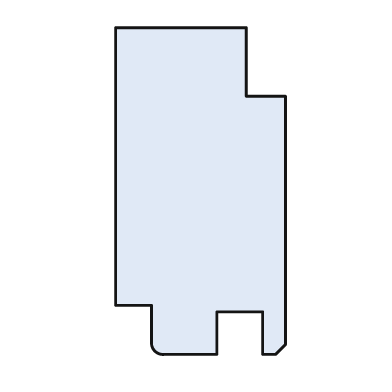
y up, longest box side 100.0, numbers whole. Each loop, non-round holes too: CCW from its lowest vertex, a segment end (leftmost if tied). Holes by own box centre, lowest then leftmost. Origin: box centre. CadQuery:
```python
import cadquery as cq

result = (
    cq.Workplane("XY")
    .moveTo(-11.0, -50.0)
    .lineTo(5.0, -50.0)
    .lineTo(5.0, -37.0)
    .lineTo(19.0, -37.0)
    .lineTo(19.0, -50.0)
    .lineTo(23.0, -50.0)
    .lineTo(26.0, -47.0)
    .lineTo(26.0, 29.0)
    .lineTo(14.0, 29.0)
    .lineTo(14.0, 50.0)
    .lineTo(-26.0, 50.0)
    .lineTo(-26.0, -35.0)
    .lineTo(-15.0, -35.0)
    .lineTo(-15.0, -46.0)
    .threePointArc((-14.0, -49.0), (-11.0, -50.0))
    .close()
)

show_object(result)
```